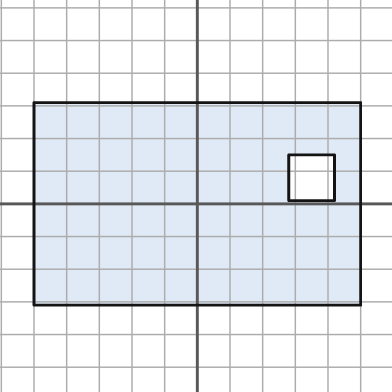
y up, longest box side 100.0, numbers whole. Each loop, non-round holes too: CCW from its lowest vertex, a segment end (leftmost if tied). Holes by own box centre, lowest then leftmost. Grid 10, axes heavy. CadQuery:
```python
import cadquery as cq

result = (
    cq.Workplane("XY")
    .moveTo(-50.0, -31.0)
    .lineTo(50.0, -31.0)
    .lineTo(50.0, 31.0)
    .lineTo(-50.0, 31.0)
    .close()
    .moveTo(28.0, 1.0)
    .lineTo(42.0, 1.0)
    .lineTo(42.0, 15.0)
    .lineTo(28.0, 15.0)
    .close()
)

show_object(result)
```